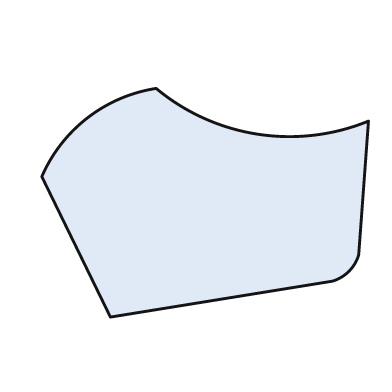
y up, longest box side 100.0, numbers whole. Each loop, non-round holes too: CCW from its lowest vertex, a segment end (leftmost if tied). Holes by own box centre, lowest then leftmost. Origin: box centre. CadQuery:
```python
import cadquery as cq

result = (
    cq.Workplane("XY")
    .moveTo(-29.0, -35.0)
    .lineTo(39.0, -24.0)
    .threePointArc((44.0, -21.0), (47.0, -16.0))
    .lineTo(50.0, 25.0)
    .threePointArc((16.0, 21.0), (-15.0, 35.0))
    .threePointArc((-36.0, 26.0), (-50.0, 8.0))
    .close()
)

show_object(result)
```